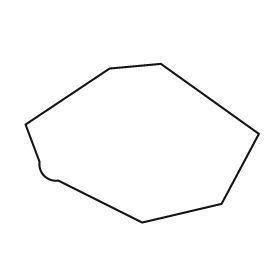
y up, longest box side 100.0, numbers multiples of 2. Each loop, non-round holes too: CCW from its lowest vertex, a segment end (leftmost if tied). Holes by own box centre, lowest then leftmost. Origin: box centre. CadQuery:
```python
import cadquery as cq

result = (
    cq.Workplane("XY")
    .moveTo(0.0, -34.0)
    .lineTo(34.0, -26.0)
    .lineTo(50.0, 4.0)
    .lineTo(8.0, 34.0)
    .lineTo(-14.0, 32.0)
    .lineTo(-50.0, 8.0)
    .lineTo(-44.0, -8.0)
    .threePointArc((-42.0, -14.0), (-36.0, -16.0))
    .close()
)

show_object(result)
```